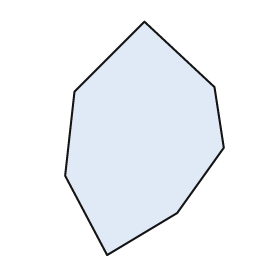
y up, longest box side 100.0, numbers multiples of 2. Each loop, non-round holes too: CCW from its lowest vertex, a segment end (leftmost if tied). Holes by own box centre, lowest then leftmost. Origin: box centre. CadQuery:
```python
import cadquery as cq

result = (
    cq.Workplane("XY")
    .moveTo(-16.0, -50.0)
    .lineTo(14.0, -32.0)
    .lineTo(34.0, -4.0)
    .lineTo(30.0, 22.0)
    .lineTo(0.0, 50.0)
    .lineTo(-30.0, 20.0)
    .lineTo(-34.0, -16.0)
    .close()
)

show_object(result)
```